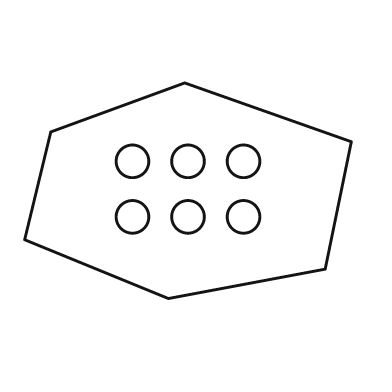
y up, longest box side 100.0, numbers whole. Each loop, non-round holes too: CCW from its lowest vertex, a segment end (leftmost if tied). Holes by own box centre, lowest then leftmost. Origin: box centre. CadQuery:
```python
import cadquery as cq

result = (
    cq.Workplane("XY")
    .moveTo(-6.0, -33.0)
    .lineTo(42.0, -24.0)
    .lineTo(50.0, 15.0)
    .lineTo(-1.0, 33.0)
    .lineTo(-42.0, 18.0)
    .lineTo(-50.0, -15.0)
    .close()
    .moveTo(-17.0, -8.0)
    .circle(5.0)
    .moveTo(0.0, -8.0)
    .circle(5.0)
    .moveTo(17.0, -8.0)
    .circle(5.0)
    .moveTo(-17.0, 9.0)
    .circle(5.0)
    .moveTo(0.0, 9.0)
    .circle(5.0)
    .moveTo(17.0, 9.0)
    .circle(5.0)
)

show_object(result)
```